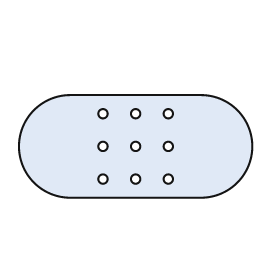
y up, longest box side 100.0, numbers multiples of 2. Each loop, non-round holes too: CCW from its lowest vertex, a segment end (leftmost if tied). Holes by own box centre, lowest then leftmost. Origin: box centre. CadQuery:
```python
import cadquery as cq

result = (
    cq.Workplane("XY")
    .moveTo(-28.0, -22.0)
    .lineTo(28.0, -22.0)
    .threePointArc((50.0, 0.0), (28.0, 22.0))
    .lineTo(-28.0, 22.0)
    .threePointArc((-50.0, 0.0), (-28.0, -22.0))
    .close()
    .moveTo(-14.0, -14.0)
    .circle(2.0)
    .moveTo(0.0, -14.0)
    .circle(2.0)
    .moveTo(14.0, -14.0)
    .circle(2.0)
    .moveTo(-14.0, 0.0)
    .circle(2.0)
    .moveTo(0.0, 0.0)
    .circle(2.0)
    .moveTo(14.0, 0.0)
    .circle(2.0)
    .moveTo(-14.0, 14.0)
    .circle(2.0)
    .moveTo(0.0, 14.0)
    .circle(2.0)
    .moveTo(14.0, 14.0)
    .circle(2.0)
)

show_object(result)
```